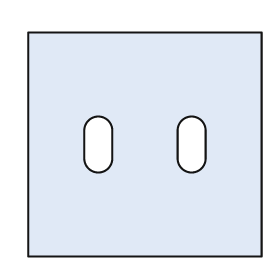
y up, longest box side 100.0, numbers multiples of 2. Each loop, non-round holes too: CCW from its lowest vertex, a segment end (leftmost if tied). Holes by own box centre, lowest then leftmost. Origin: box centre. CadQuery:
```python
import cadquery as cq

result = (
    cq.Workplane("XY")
    .moveTo(-50.0, -48.0)
    .lineTo(50.0, -48.0)
    .lineTo(50.0, 48.0)
    .lineTo(-50.0, 48.0)
    .close()
    .moveTo(-26.0, -6.0)
    .threePointArc((-20.0, -12.0), (-14.0, -6.0))
    .lineTo(-14.0, 6.0)
    .threePointArc((-20.0, 12.0), (-26.0, 6.0))
    .close()
    .moveTo(14.0, -6.0)
    .threePointArc((20.0, -12.0), (26.0, -6.0))
    .lineTo(26.0, 6.0)
    .threePointArc((20.0, 12.0), (14.0, 6.0))
    .close()
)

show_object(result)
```